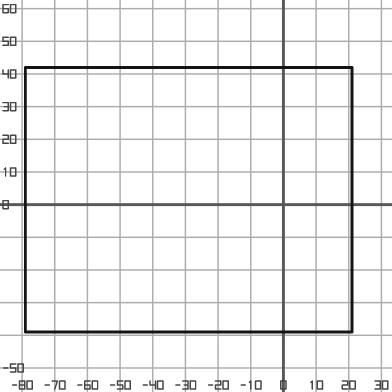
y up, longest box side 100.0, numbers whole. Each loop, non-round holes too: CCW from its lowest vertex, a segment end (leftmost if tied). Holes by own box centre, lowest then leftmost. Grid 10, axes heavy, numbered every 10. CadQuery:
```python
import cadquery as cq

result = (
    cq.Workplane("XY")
    .moveTo(-79.0, -39.0)
    .lineTo(21.0, -39.0)
    .lineTo(21.0, 42.0)
    .lineTo(-79.0, 42.0)
    .close()
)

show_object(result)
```